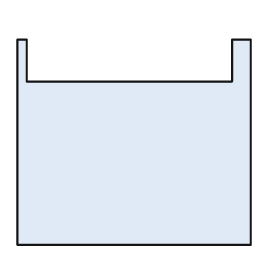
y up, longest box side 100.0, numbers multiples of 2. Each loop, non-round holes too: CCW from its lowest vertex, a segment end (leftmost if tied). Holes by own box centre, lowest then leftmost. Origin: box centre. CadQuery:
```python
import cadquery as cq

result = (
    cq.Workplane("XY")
    .moveTo(-50.0, -44.0)
    .lineTo(50.0, -44.0)
    .lineTo(50.0, 44.0)
    .lineTo(42.0, 44.0)
    .lineTo(42.0, 26.0)
    .lineTo(-46.0, 26.0)
    .lineTo(-46.0, 44.0)
    .lineTo(-50.0, 44.0)
    .close()
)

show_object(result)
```